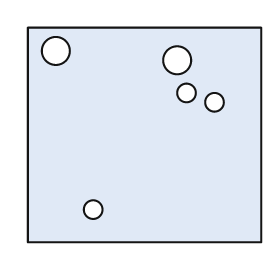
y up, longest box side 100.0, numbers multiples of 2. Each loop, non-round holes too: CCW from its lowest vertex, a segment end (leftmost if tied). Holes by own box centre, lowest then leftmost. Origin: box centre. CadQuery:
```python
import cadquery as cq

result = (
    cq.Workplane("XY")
    .moveTo(-50.0, -46.0)
    .lineTo(50.0, -46.0)
    .lineTo(50.0, 46.0)
    .lineTo(-50.0, 46.0)
    .close()
    .moveTo(-22.0, -32.0)
    .circle(4.0)
    .moveTo(30.0, 14.0)
    .circle(4.0)
    .moveTo(18.0, 18.0)
    .circle(4.0)
    .moveTo(14.0, 32.0)
    .circle(6.0)
    .moveTo(-38.0, 36.0)
    .circle(6.0)
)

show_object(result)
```